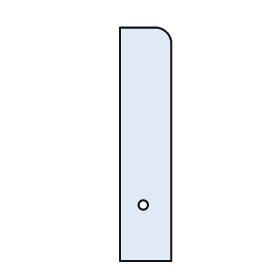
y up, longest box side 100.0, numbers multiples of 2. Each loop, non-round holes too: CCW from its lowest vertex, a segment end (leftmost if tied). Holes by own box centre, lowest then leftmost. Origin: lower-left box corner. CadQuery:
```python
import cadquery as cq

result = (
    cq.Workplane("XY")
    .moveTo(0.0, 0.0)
    .lineTo(22.0, 0.0)
    .lineTo(22.0, 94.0)
    .threePointArc((20.0, 98.0), (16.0, 100.0))
    .lineTo(0.0, 100.0)
    .close()
    .moveTo(10.0, 24.0)
    .circle(2.0)
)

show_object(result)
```